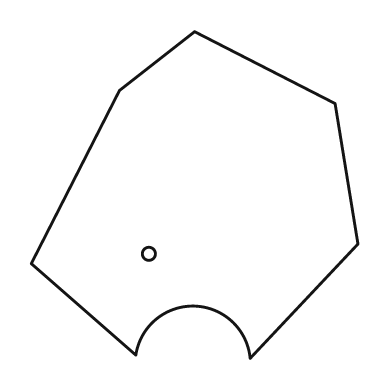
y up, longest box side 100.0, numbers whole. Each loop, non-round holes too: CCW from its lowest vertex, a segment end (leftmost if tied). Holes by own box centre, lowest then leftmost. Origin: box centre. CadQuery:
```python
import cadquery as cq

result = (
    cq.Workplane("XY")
    .moveTo(17.0, -50.0)
    .lineTo(50.0, -15.0)
    .lineTo(43.0, 28.0)
    .lineTo(0.0, 50.0)
    .lineTo(-23.0, 32.0)
    .lineTo(-50.0, -21.0)
    .lineTo(-18.0, -49.0)
    .threePointArc((0.0, -34.0), (17.0, -50.0))
    .close()
    .moveTo(-14.0, -18.0)
    .circle(2.0)
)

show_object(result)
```